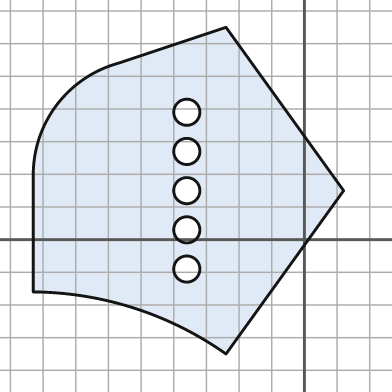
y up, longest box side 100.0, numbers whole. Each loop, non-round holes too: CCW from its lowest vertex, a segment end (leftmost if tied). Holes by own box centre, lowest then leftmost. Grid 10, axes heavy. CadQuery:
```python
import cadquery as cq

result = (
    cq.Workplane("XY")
    .moveTo(-24.0, -35.0)
    .lineTo(12.0, 15.0)
    .lineTo(-24.0, 65.0)
    .lineTo(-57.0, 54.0)
    .threePointArc((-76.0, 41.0), (-83.0, 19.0))
    .lineTo(-83.0, -16.0)
    .threePointArc((-52.0, -21.0), (-24.0, -35.0))
    .close()
    .moveTo(-36.0, -9.0)
    .circle(4.0)
    .moveTo(-36.0, 3.0)
    .circle(4.0)
    .moveTo(-36.0, 15.0)
    .circle(4.0)
    .moveTo(-36.0, 27.0)
    .circle(4.0)
    .moveTo(-36.0, 39.0)
    .circle(4.0)
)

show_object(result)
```